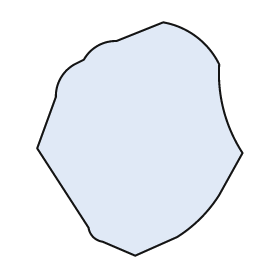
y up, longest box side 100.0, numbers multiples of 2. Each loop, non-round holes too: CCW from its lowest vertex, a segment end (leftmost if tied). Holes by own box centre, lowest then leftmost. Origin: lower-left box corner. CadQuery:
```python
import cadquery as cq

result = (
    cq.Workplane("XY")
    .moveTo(42.0, 0.0)
    .lineTo(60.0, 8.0)
    .threePointArc((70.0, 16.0), (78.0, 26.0))
    .lineTo(88.0, 44.0)
    .threePointArc((80.0, 62.0), (78.0, 82.0))
    .threePointArc((68.0, 94.0), (54.0, 100.0))
    .lineTo(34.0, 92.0)
    .threePointArc((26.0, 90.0), (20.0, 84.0))
    .lineTo(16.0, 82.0)
    .threePointArc((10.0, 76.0), (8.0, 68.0))
    .lineTo(0.0, 46.0)
    .lineTo(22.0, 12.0)
    .threePointArc((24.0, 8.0), (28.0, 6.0))
    .close()
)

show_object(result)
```